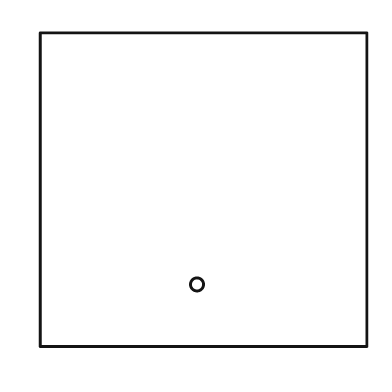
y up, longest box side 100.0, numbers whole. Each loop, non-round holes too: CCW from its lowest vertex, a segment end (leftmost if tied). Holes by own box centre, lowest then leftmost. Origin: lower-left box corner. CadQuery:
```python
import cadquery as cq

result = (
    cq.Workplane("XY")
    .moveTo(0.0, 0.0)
    .lineTo(100.0, 0.0)
    .lineTo(100.0, 96.0)
    .lineTo(0.0, 96.0)
    .close()
    .moveTo(48.0, 19.0)
    .circle(2.0)
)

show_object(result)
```